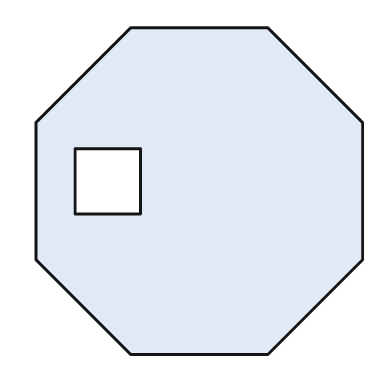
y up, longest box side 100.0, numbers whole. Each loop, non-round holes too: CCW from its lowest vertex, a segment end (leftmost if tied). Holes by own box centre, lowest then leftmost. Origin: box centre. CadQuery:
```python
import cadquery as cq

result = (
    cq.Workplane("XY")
    .moveTo(-21.0, -50.0)
    .lineTo(21.0, -50.0)
    .lineTo(50.0, -21.0)
    .lineTo(50.0, 21.0)
    .lineTo(21.0, 50.0)
    .lineTo(-21.0, 50.0)
    .lineTo(-50.0, 21.0)
    .lineTo(-50.0, -21.0)
    .close()
    .moveTo(-38.0, -7.0)
    .lineTo(-18.0, -7.0)
    .lineTo(-18.0, 13.0)
    .lineTo(-38.0, 13.0)
    .close()
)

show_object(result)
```